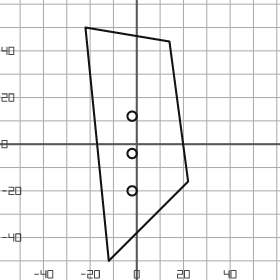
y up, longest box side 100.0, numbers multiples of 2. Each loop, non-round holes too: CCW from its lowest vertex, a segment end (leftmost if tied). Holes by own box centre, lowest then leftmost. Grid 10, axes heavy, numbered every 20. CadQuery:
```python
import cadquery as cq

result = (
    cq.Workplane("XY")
    .moveTo(-12.0, -50.0)
    .lineTo(22.0, -16.0)
    .lineTo(14.0, 44.0)
    .lineTo(-22.0, 50.0)
    .close()
    .moveTo(-2.0, -20.0)
    .circle(2.0)
    .moveTo(-2.0, -4.0)
    .circle(2.0)
    .moveTo(-2.0, 12.0)
    .circle(2.0)
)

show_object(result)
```